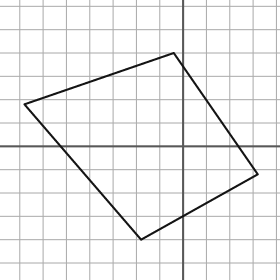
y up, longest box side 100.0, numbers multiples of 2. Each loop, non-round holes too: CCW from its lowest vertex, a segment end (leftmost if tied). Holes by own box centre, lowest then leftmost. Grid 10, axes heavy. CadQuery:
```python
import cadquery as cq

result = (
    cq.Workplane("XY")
    .moveTo(-18.0, -40.0)
    .lineTo(32.0, -12.0)
    .lineTo(-4.0, 40.0)
    .lineTo(-68.0, 18.0)
    .close()
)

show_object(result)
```